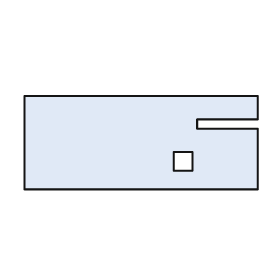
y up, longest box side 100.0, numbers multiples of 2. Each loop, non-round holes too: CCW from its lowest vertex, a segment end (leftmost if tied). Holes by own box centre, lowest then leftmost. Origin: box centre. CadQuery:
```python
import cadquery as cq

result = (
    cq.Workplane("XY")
    .moveTo(-50.0, -20.0)
    .lineTo(50.0, -20.0)
    .lineTo(50.0, 6.0)
    .lineTo(24.0, 6.0)
    .lineTo(24.0, 10.0)
    .lineTo(50.0, 10.0)
    .lineTo(50.0, 20.0)
    .lineTo(-50.0, 20.0)
    .close()
    .moveTo(14.0, -12.0)
    .lineTo(22.0, -12.0)
    .lineTo(22.0, -4.0)
    .lineTo(14.0, -4.0)
    .close()
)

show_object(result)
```